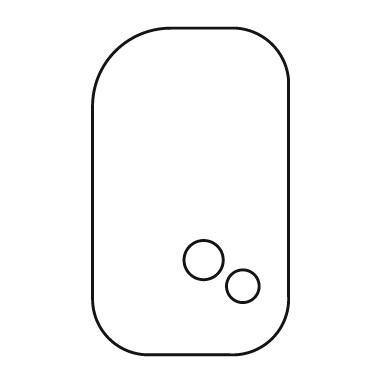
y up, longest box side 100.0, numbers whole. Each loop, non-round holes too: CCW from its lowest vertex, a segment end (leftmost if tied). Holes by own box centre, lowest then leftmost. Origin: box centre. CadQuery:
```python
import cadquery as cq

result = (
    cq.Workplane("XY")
    .moveTo(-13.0, -50.0)
    .lineTo(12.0, -50.0)
    .threePointArc((25.0, -45.0), (30.0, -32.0))
    .lineTo(30.0, 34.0)
    .threePointArc((25.0, 45.0), (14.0, 50.0))
    .lineTo(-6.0, 50.0)
    .threePointArc((-23.0, 43.0), (-30.0, 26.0))
    .lineTo(-30.0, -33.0)
    .threePointArc((-25.0, -45.0), (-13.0, -50.0))
    .close()
    .moveTo(16.0, -29.0)
    .circle(5.0)
    .moveTo(4.0, -21.0)
    .circle(6.0)
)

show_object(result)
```